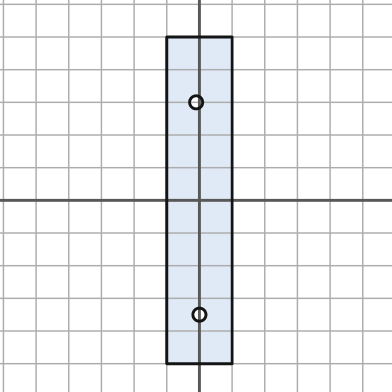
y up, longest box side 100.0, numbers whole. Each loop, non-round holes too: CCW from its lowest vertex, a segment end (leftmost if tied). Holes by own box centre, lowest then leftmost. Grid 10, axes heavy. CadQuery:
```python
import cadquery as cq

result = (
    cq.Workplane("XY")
    .moveTo(-10.0, -50.0)
    .lineTo(10.0, -50.0)
    .lineTo(10.0, 50.0)
    .lineTo(-10.0, 50.0)
    .close()
    .moveTo(0.0, -35.0)
    .circle(2.0)
    .moveTo(-1.0, 30.0)
    .circle(2.0)
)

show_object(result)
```